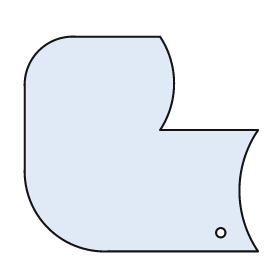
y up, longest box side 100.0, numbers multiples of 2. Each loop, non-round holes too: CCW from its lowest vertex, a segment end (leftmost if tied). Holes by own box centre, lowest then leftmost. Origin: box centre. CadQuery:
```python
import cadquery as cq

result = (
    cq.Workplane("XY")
    .moveTo(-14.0, -46.0)
    .lineTo(50.0, -46.0)
    .threePointArc((42.0, -20.0), (50.0, 6.0))
    .lineTo(8.0, 6.0)
    .threePointArc((14.0, 26.0), (8.0, 46.0))
    .lineTo(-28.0, 46.0)
    .threePointArc((-44.0, 40.0), (-50.0, 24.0))
    .lineTo(-50.0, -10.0)
    .threePointArc((-40.0, -36.0), (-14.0, -46.0))
    .close()
    .moveTo(34.0, -38.0)
    .circle(2.0)
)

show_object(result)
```